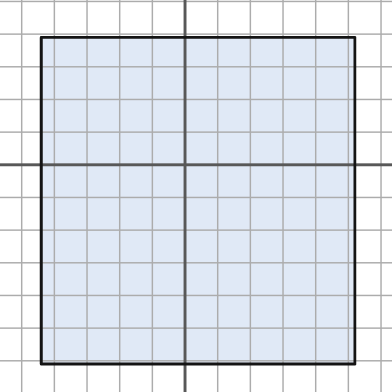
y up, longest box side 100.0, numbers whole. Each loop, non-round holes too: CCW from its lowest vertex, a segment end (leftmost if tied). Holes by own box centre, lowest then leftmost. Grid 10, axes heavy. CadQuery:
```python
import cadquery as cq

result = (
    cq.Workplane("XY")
    .moveTo(-44.0, -61.0)
    .lineTo(52.0, -61.0)
    .lineTo(52.0, 39.0)
    .lineTo(-44.0, 39.0)
    .close()
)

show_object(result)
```